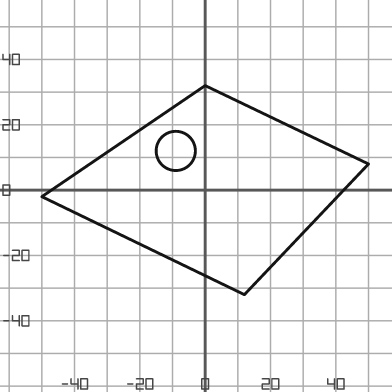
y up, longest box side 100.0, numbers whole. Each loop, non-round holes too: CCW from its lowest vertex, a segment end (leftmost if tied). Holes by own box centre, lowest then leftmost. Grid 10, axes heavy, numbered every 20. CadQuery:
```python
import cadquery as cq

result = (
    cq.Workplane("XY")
    .moveTo(12.0, -32.0)
    .lineTo(50.0, 8.0)
    .lineTo(0.0, 32.0)
    .lineTo(-50.0, -2.0)
    .close()
    .moveTo(-9.0, 12.0)
    .circle(6.0)
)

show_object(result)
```